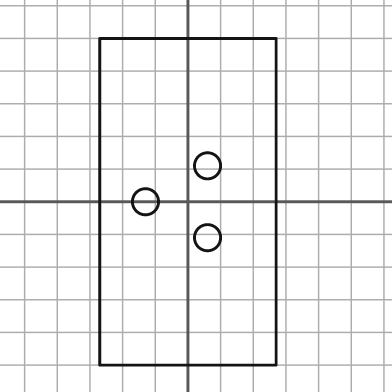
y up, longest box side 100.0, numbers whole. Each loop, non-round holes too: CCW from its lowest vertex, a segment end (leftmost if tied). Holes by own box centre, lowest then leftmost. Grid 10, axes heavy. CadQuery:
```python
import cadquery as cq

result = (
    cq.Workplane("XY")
    .moveTo(-27.0, -50.0)
    .lineTo(27.0, -50.0)
    .lineTo(27.0, 50.0)
    .lineTo(-27.0, 50.0)
    .close()
    .moveTo(6.0, -11.0)
    .circle(4.0)
    .moveTo(-13.0, 0.0)
    .circle(4.0)
    .moveTo(6.0, 11.0)
    .circle(4.0)
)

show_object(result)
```